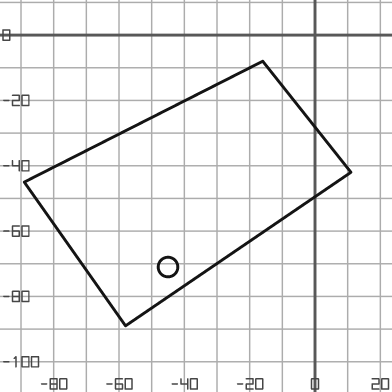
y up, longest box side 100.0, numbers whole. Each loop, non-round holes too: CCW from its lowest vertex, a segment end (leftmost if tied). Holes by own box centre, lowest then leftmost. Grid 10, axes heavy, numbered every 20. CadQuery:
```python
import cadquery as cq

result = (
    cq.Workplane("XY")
    .moveTo(-58.0, -89.0)
    .lineTo(11.0, -42.0)
    .lineTo(-16.0, -8.0)
    .lineTo(-89.0, -45.0)
    .close()
    .moveTo(-45.0, -71.0)
    .circle(3.0)
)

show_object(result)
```